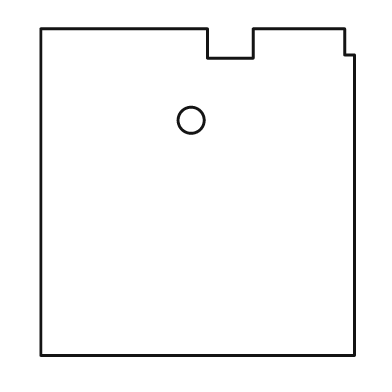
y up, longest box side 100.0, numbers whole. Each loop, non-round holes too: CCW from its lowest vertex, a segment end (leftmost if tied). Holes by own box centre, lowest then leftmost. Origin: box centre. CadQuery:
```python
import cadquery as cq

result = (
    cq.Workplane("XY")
    .moveTo(-48.0, -50.0)
    .lineTo(48.0, -50.0)
    .lineTo(48.0, 42.0)
    .lineTo(45.0, 42.0)
    .lineTo(45.0, 50.0)
    .lineTo(17.0, 50.0)
    .lineTo(17.0, 41.0)
    .lineTo(3.0, 41.0)
    .lineTo(3.0, 50.0)
    .lineTo(-48.0, 50.0)
    .close()
    .moveTo(-2.0, 22.0)
    .circle(4.0)
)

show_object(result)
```